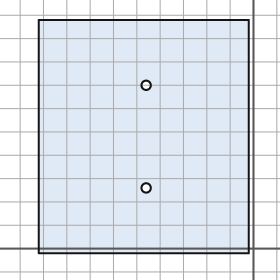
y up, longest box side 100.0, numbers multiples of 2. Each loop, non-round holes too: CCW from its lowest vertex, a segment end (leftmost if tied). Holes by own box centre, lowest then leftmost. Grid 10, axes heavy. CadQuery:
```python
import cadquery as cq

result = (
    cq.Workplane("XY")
    .moveTo(-92.0, -2.0)
    .lineTo(-2.0, -2.0)
    .lineTo(-2.0, 98.0)
    .lineTo(-92.0, 98.0)
    .close()
    .moveTo(-46.0, 26.0)
    .circle(2.0)
    .moveTo(-46.0, 70.0)
    .circle(2.0)
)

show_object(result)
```